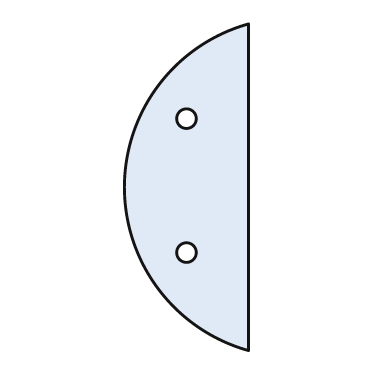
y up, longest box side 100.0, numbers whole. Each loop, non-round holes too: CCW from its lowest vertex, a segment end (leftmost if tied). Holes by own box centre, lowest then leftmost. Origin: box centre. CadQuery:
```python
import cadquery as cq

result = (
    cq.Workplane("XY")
    .moveTo(19.0, -50.0)
    .lineTo(19.0, 50.0)
    .threePointArc((-19.0, 0.0), (19.0, -50.0))
    .close()
    .moveTo(0.0, -20.0)
    .circle(3.0)
    .moveTo(0.0, 21.0)
    .circle(3.0)
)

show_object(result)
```